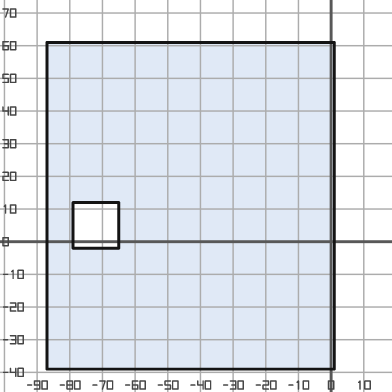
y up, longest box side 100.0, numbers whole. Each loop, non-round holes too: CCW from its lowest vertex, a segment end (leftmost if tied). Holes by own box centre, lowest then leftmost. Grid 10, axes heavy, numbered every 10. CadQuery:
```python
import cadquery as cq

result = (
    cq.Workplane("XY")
    .moveTo(-87.0, -39.0)
    .lineTo(1.0, -39.0)
    .lineTo(1.0, 61.0)
    .lineTo(-87.0, 61.0)
    .close()
    .moveTo(-79.0, -2.0)
    .lineTo(-65.0, -2.0)
    .lineTo(-65.0, 12.0)
    .lineTo(-79.0, 12.0)
    .close()
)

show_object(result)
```